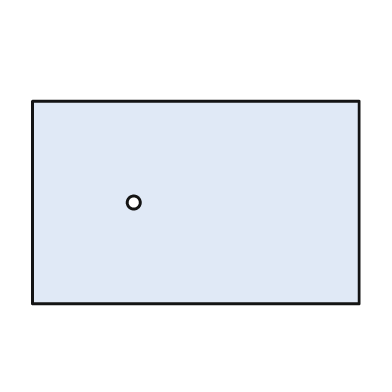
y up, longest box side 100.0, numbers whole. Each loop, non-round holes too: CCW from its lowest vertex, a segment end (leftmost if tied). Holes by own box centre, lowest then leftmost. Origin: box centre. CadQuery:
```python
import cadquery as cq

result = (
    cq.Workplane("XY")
    .moveTo(-50.0, -31.0)
    .lineTo(50.0, -31.0)
    .lineTo(50.0, 31.0)
    .lineTo(-50.0, 31.0)
    .close()
    .moveTo(-19.0, 0.0)
    .circle(2.0)
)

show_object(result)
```